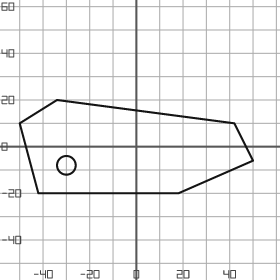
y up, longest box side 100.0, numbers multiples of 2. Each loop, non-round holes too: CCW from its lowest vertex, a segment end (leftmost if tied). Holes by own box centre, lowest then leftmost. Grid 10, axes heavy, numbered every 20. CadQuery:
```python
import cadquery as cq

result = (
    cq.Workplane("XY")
    .moveTo(-42.0, -20.0)
    .lineTo(18.0, -20.0)
    .lineTo(50.0, -6.0)
    .lineTo(42.0, 10.0)
    .lineTo(-34.0, 20.0)
    .lineTo(-50.0, 10.0)
    .close()
    .moveTo(-30.0, -8.0)
    .circle(4.0)
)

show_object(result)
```